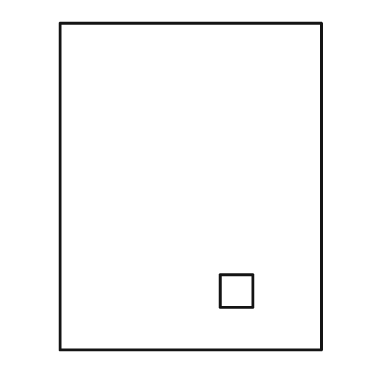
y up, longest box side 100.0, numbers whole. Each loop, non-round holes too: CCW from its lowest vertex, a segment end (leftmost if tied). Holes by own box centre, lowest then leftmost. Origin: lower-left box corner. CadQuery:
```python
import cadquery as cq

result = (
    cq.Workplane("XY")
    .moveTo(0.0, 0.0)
    .lineTo(80.0, 0.0)
    .lineTo(80.0, 100.0)
    .lineTo(0.0, 100.0)
    .close()
    .moveTo(49.0, 13.0)
    .lineTo(59.0, 13.0)
    .lineTo(59.0, 23.0)
    .lineTo(49.0, 23.0)
    .close()
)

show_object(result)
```